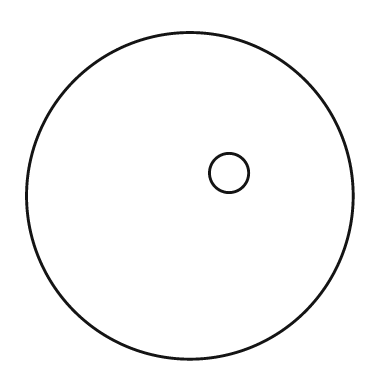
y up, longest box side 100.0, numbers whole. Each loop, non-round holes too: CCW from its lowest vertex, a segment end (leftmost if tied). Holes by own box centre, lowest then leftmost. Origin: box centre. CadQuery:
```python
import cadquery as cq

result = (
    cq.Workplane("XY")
    .moveTo(0.0, 0.0)
    .circle(50.0)
    .moveTo(12.0, 7.0)
    .circle(6.0)
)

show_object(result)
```